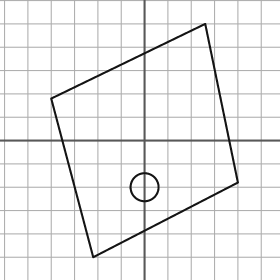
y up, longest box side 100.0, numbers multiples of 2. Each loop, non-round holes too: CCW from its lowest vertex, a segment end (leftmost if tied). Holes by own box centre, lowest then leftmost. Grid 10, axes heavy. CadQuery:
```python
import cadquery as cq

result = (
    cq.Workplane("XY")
    .moveTo(-22.0, -50.0)
    .lineTo(40.0, -18.0)
    .lineTo(26.0, 50.0)
    .lineTo(-40.0, 18.0)
    .close()
    .moveTo(0.0, -20.0)
    .circle(6.0)
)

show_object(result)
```